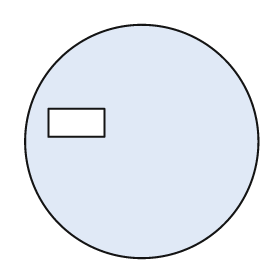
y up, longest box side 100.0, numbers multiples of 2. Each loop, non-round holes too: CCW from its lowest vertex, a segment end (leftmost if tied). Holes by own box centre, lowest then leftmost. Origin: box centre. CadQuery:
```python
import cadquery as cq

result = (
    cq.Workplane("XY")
    .moveTo(0.0, 0.0)
    .circle(50.0)
    .moveTo(-40.0, 2.0)
    .lineTo(-16.0, 2.0)
    .lineTo(-16.0, 14.0)
    .lineTo(-40.0, 14.0)
    .close()
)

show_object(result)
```